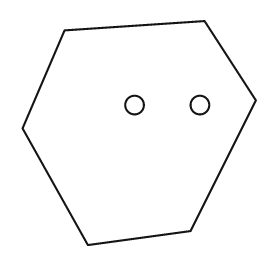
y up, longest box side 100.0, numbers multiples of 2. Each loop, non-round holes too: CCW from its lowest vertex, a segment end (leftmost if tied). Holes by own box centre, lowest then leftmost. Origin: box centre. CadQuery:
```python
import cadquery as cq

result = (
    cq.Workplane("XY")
    .moveTo(-22.0, -48.0)
    .lineTo(22.0, -42.0)
    .lineTo(50.0, 14.0)
    .lineTo(28.0, 48.0)
    .lineTo(-32.0, 44.0)
    .lineTo(-50.0, 2.0)
    .close()
    .moveTo(-2.0, 12.0)
    .circle(4.0)
    .moveTo(26.0, 12.0)
    .circle(4.0)
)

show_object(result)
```